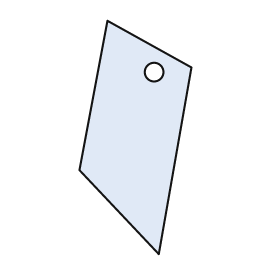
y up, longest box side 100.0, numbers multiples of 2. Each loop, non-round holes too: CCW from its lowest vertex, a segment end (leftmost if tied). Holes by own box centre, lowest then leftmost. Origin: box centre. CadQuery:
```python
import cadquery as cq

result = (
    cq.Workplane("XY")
    .moveTo(10.0, -50.0)
    .lineTo(24.0, 30.0)
    .lineTo(-12.0, 50.0)
    .lineTo(-24.0, -14.0)
    .close()
    .moveTo(8.0, 28.0)
    .circle(4.0)
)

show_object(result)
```